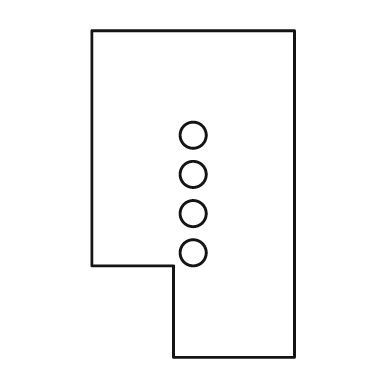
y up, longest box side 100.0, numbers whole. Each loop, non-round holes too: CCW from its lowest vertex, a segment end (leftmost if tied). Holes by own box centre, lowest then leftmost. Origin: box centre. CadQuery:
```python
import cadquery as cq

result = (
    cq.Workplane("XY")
    .moveTo(-6.0, -50.0)
    .lineTo(31.0, -50.0)
    .lineTo(31.0, 50.0)
    .lineTo(-31.0, 50.0)
    .lineTo(-31.0, -22.0)
    .lineTo(-6.0, -22.0)
    .close()
    .moveTo(0.0, -18.0)
    .circle(4.0)
    .moveTo(0.0, -6.0)
    .circle(4.0)
    .moveTo(0.0, 6.0)
    .circle(4.0)
    .moveTo(0.0, 18.0)
    .circle(4.0)
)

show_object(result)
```